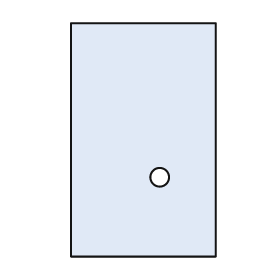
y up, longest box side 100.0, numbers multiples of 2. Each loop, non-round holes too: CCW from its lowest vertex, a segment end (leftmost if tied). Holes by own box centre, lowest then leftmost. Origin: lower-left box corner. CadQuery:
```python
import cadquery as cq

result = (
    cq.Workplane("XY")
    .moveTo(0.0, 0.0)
    .lineTo(62.0, 0.0)
    .lineTo(62.0, 100.0)
    .lineTo(0.0, 100.0)
    .close()
    .moveTo(38.0, 34.0)
    .circle(4.0)
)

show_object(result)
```